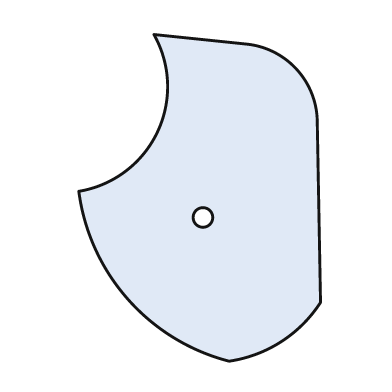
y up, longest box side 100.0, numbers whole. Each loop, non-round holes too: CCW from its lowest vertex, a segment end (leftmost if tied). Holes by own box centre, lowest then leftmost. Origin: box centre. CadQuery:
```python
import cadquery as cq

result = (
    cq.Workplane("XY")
    .moveTo(9.0, -50.0)
    .threePointArc((25.0, -44.0), (37.0, -32.0))
    .lineTo(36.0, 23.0)
    .threePointArc((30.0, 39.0), (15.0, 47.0))
    .lineTo(-14.0, 50.0)
    .threePointArc((-13.0, 20.0), (-37.0, 2.0))
    .threePointArc((-22.0, -31.0), (9.0, -50.0))
    .close()
    .moveTo(1.0, -6.0)
    .circle(3.0)
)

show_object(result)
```